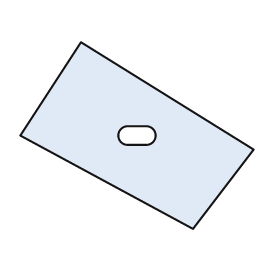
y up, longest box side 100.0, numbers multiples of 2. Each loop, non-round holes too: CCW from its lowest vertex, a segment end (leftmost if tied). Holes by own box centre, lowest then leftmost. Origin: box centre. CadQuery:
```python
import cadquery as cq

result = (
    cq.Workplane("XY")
    .moveTo(24.0, -40.0)
    .lineTo(50.0, -6.0)
    .lineTo(-24.0, 40.0)
    .lineTo(-50.0, 0.0)
    .close()
    .moveTo(-4.0, -4.0)
    .lineTo(4.0, -4.0)
    .threePointArc((8.0, 0.0), (4.0, 4.0))
    .lineTo(-4.0, 4.0)
    .threePointArc((-8.0, 0.0), (-4.0, -4.0))
    .close()
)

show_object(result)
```